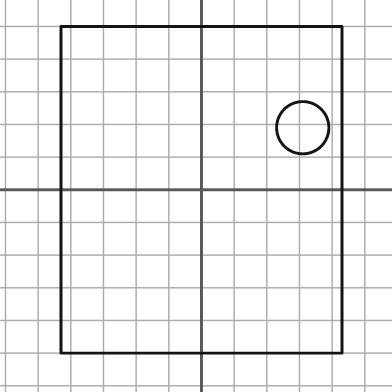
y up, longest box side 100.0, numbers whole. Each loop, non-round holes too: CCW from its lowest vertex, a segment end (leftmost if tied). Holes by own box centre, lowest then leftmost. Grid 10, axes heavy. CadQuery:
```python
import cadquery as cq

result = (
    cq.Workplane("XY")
    .moveTo(-43.0, -50.0)
    .lineTo(43.0, -50.0)
    .lineTo(43.0, 50.0)
    .lineTo(-43.0, 50.0)
    .close()
    .moveTo(31.0, 19.0)
    .circle(8.0)
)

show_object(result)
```